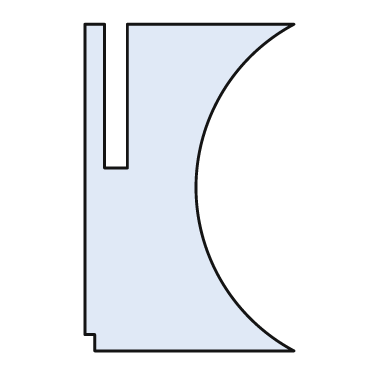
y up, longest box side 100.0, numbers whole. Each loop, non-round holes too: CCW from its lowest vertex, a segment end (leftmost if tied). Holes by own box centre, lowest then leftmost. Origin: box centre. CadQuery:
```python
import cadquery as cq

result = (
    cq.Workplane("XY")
    .moveTo(-29.0, -50.0)
    .lineTo(32.0, -50.0)
    .threePointArc((2.0, 0.0), (32.0, 50.0))
    .lineTo(-19.0, 50.0)
    .lineTo(-19.0, 6.0)
    .lineTo(-26.0, 6.0)
    .lineTo(-26.0, 50.0)
    .lineTo(-32.0, 50.0)
    .lineTo(-32.0, -45.0)
    .lineTo(-29.0, -45.0)
    .close()
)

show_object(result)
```